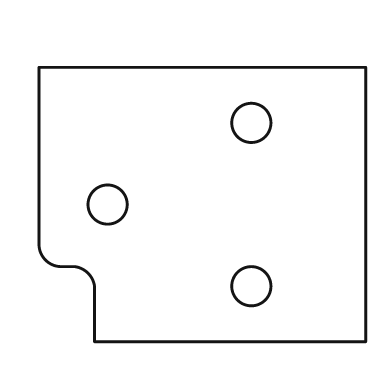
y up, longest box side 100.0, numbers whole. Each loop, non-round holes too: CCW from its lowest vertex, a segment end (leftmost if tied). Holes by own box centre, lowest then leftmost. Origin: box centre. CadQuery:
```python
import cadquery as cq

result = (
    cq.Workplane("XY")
    .moveTo(-33.0, -42.0)
    .lineTo(50.0, -42.0)
    .lineTo(50.0, 42.0)
    .lineTo(-50.0, 42.0)
    .lineTo(-50.0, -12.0)
    .threePointArc((-48.0, -17.0), (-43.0, -19.0))
    .lineTo(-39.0, -19.0)
    .threePointArc((-35.0, -21.0), (-33.0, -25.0))
    .close()
    .moveTo(15.0, -25.0)
    .circle(6.0)
    .moveTo(-29.0, 0.0)
    .circle(6.0)
    .moveTo(15.0, 25.0)
    .circle(6.0)
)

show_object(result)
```